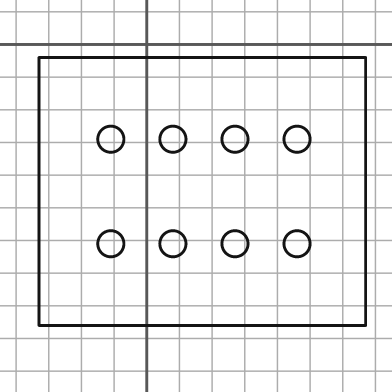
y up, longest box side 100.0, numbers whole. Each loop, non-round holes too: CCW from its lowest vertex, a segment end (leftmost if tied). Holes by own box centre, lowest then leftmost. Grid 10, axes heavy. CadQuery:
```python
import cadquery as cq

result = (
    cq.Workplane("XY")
    .moveTo(-33.0, -86.0)
    .lineTo(67.0, -86.0)
    .lineTo(67.0, -4.0)
    .lineTo(-33.0, -4.0)
    .close()
    .moveTo(-11.0, -61.0)
    .circle(4.0)
    .moveTo(8.0, -61.0)
    .circle(4.0)
    .moveTo(27.0, -61.0)
    .circle(4.0)
    .moveTo(46.0, -61.0)
    .circle(4.0)
    .moveTo(-11.0, -29.0)
    .circle(4.0)
    .moveTo(8.0, -29.0)
    .circle(4.0)
    .moveTo(27.0, -29.0)
    .circle(4.0)
    .moveTo(46.0, -29.0)
    .circle(4.0)
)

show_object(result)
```